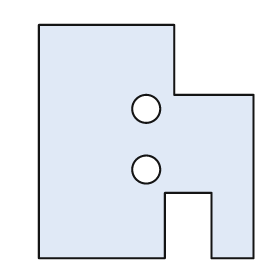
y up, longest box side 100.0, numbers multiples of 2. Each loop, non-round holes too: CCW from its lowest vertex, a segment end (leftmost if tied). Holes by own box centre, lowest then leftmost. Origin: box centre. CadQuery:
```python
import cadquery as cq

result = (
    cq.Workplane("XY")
    .moveTo(-46.0, -50.0)
    .lineTo(8.0, -50.0)
    .lineTo(8.0, -22.0)
    .lineTo(28.0, -22.0)
    .lineTo(28.0, -50.0)
    .lineTo(46.0, -50.0)
    .lineTo(46.0, 20.0)
    .lineTo(12.0, 20.0)
    .lineTo(12.0, 50.0)
    .lineTo(-46.0, 50.0)
    .close()
    .moveTo(0.0, -12.0)
    .circle(6.0)
    .moveTo(0.0, 14.0)
    .circle(6.0)
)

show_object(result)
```